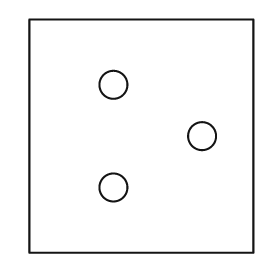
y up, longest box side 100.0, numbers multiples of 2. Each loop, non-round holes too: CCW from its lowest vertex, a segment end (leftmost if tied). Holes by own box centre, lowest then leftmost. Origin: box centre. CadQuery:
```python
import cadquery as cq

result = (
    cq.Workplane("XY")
    .moveTo(-48.0, -50.0)
    .lineTo(48.0, -50.0)
    .lineTo(48.0, 50.0)
    .lineTo(-48.0, 50.0)
    .close()
    .moveTo(-12.0, -22.0)
    .circle(6.0)
    .moveTo(26.0, 0.0)
    .circle(6.0)
    .moveTo(-12.0, 22.0)
    .circle(6.0)
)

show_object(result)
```